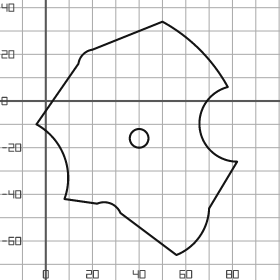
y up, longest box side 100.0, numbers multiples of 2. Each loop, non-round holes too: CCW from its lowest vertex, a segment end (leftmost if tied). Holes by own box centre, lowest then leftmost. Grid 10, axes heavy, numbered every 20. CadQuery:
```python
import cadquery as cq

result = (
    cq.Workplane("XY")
    .moveTo(56.0, -66.0)
    .threePointArc((66.0, -58.0), (70.0, -46.0))
    .lineTo(82.0, -26.0)
    .threePointArc((66.0, -12.0), (78.0, 6.0))
    .threePointArc((66.0, 22.0), (50.0, 34.0))
    .lineTo(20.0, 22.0)
    .threePointArc((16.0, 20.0), (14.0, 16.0))
    .lineTo(-4.0, -10.0)
    .threePointArc((8.0, -24.0), (8.0, -42.0))
    .lineTo(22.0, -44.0)
    .threePointArc((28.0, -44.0), (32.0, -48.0))
    .close()
    .moveTo(40.0, -16.0)
    .circle(4.0)
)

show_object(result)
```